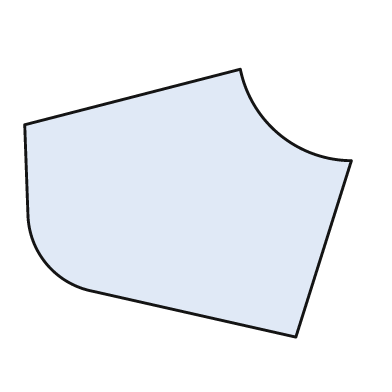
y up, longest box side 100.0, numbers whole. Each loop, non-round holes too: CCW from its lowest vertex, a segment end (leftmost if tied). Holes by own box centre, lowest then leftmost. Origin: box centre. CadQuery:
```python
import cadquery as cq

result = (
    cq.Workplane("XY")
    .moveTo(33.0, -41.0)
    .lineTo(50.0, 13.0)
    .threePointArc((28.0, 21.0), (16.0, 41.0))
    .lineTo(-50.0, 24.0)
    .lineTo(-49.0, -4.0)
    .threePointArc((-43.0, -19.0), (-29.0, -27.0))
    .close()
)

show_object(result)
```